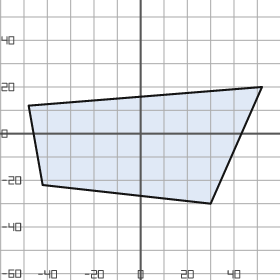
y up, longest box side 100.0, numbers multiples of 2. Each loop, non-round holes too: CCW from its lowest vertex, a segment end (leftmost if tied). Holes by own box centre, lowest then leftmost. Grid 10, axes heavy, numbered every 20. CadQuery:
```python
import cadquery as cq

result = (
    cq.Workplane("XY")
    .moveTo(30.0, -30.0)
    .lineTo(52.0, 20.0)
    .lineTo(-48.0, 12.0)
    .lineTo(-42.0, -22.0)
    .close()
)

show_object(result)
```